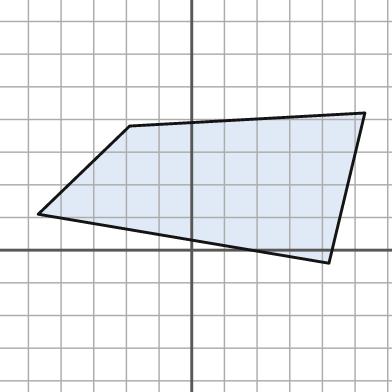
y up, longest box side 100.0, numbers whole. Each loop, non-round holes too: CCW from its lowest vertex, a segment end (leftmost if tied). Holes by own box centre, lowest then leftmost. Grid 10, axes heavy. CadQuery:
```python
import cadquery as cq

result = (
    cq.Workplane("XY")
    .moveTo(42.0, -4.0)
    .lineTo(53.0, 42.0)
    .lineTo(-19.0, 38.0)
    .lineTo(-47.0, 11.0)
    .close()
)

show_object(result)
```